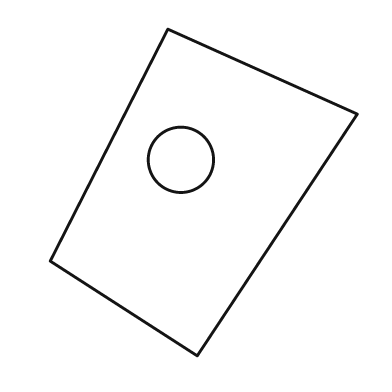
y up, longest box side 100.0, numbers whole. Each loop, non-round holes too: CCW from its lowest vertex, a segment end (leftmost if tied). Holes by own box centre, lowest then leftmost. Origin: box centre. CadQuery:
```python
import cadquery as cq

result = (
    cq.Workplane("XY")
    .moveTo(-2.0, -50.0)
    .lineTo(47.0, 24.0)
    .lineTo(-11.0, 50.0)
    .lineTo(-47.0, -21.0)
    .close()
    .moveTo(-7.0, 10.0)
    .circle(10.0)
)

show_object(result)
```